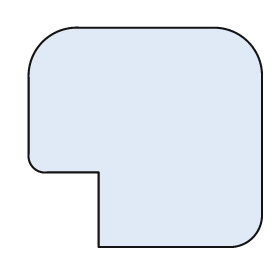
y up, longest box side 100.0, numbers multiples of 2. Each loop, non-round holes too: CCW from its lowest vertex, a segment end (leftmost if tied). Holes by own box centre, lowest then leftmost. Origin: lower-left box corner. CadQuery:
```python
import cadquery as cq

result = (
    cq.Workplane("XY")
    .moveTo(30.0, 0.0)
    .lineTo(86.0, 0.0)
    .threePointArc((96.0, 4.0), (100.0, 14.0))
    .lineTo(100.0, 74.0)
    .threePointArc((94.0, 88.0), (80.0, 94.0))
    .lineTo(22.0, 94.0)
    .threePointArc((6.0, 88.0), (0.0, 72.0))
    .lineTo(0.0, 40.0)
    .threePointArc((2.0, 34.0), (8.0, 32.0))
    .lineTo(30.0, 32.0)
    .close()
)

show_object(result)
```